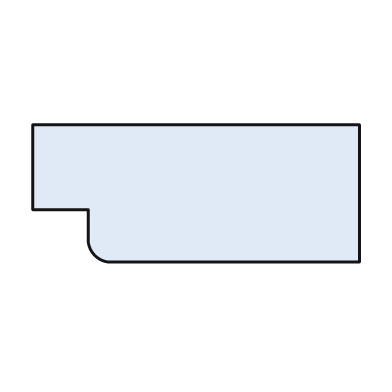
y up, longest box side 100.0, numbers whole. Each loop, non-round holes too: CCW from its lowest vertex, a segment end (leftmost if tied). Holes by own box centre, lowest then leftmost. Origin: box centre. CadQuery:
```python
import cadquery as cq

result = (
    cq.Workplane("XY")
    .moveTo(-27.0, -21.0)
    .lineTo(50.0, -21.0)
    .lineTo(50.0, 21.0)
    .lineTo(-50.0, 21.0)
    .lineTo(-50.0, -5.0)
    .lineTo(-33.0, -5.0)
    .lineTo(-33.0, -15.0)
    .threePointArc((-31.0, -19.0), (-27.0, -21.0))
    .close()
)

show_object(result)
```